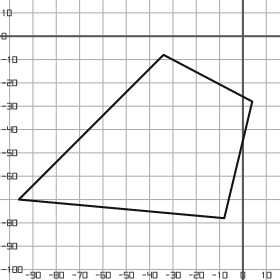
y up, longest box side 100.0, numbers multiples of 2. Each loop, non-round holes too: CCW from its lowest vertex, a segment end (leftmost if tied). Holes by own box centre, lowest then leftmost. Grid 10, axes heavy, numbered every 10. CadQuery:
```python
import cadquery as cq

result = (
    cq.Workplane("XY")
    .moveTo(-8.0, -78.0)
    .lineTo(4.0, -28.0)
    .lineTo(-34.0, -8.0)
    .lineTo(-96.0, -70.0)
    .close()
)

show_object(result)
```